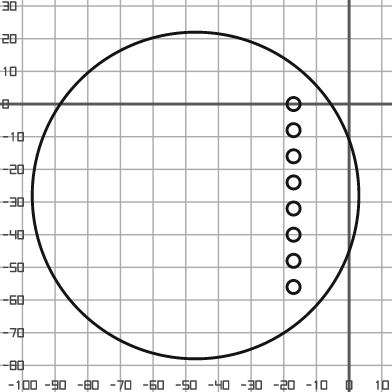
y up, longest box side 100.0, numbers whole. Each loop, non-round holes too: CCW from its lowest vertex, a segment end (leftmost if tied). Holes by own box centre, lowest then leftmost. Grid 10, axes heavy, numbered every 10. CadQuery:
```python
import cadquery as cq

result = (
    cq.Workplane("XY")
    .moveTo(-47.0, -28.0)
    .circle(50.0)
    .moveTo(-17.0, -56.0)
    .circle(2.0)
    .moveTo(-17.0, -48.0)
    .circle(2.0)
    .moveTo(-17.0, -40.0)
    .circle(2.0)
    .moveTo(-17.0, -32.0)
    .circle(2.0)
    .moveTo(-17.0, -24.0)
    .circle(2.0)
    .moveTo(-17.0, -16.0)
    .circle(2.0)
    .moveTo(-17.0, -8.0)
    .circle(2.0)
    .moveTo(-17.0, 0.0)
    .circle(2.0)
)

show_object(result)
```